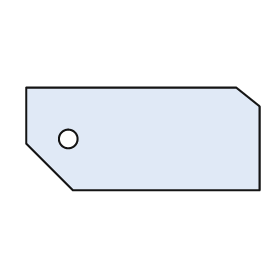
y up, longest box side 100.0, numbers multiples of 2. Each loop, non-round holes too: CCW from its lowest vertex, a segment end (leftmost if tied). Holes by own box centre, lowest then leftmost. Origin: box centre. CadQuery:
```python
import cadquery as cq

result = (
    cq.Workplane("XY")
    .moveTo(-30.0, -22.0)
    .lineTo(50.0, -22.0)
    .lineTo(50.0, 14.0)
    .lineTo(40.0, 22.0)
    .lineTo(-50.0, 22.0)
    .lineTo(-50.0, -2.0)
    .close()
    .moveTo(-32.0, 0.0)
    .circle(4.0)
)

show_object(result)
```